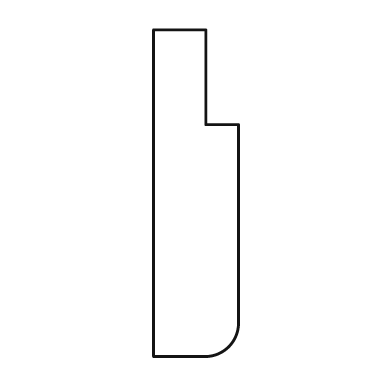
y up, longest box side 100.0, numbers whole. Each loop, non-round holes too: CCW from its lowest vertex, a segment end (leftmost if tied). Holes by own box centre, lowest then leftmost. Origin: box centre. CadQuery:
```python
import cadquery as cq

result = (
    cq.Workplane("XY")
    .moveTo(-13.0, -50.0)
    .lineTo(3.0, -50.0)
    .threePointArc((10.0, -47.0), (13.0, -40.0))
    .lineTo(13.0, 21.0)
    .lineTo(3.0, 21.0)
    .lineTo(3.0, 50.0)
    .lineTo(-13.0, 50.0)
    .close()
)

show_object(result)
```